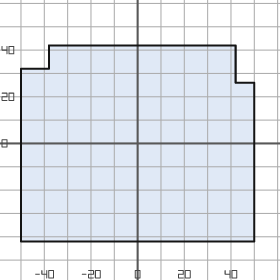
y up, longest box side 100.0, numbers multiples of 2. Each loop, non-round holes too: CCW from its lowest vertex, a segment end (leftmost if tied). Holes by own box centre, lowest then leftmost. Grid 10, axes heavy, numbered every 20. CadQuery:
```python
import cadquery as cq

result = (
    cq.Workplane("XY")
    .moveTo(-50.0, -42.0)
    .lineTo(50.0, -42.0)
    .lineTo(50.0, 26.0)
    .lineTo(42.0, 26.0)
    .lineTo(42.0, 42.0)
    .lineTo(-38.0, 42.0)
    .lineTo(-38.0, 32.0)
    .lineTo(-50.0, 32.0)
    .close()
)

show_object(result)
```